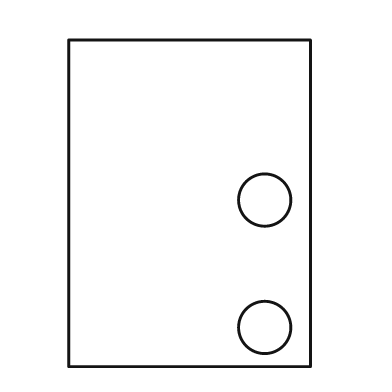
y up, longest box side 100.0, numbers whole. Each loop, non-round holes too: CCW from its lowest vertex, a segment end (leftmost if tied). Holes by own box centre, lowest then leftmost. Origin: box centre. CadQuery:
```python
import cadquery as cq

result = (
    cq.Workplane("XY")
    .moveTo(-37.0, -50.0)
    .lineTo(37.0, -50.0)
    .lineTo(37.0, 50.0)
    .lineTo(-37.0, 50.0)
    .close()
    .moveTo(23.0, -38.0)
    .circle(8.0)
    .moveTo(23.0, 1.0)
    .circle(8.0)
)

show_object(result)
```